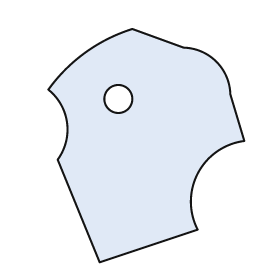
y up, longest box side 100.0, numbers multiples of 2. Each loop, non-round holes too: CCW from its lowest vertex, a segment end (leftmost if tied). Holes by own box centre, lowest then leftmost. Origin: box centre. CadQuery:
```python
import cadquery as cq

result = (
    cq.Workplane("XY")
    .moveTo(-20.0, -50.0)
    .lineTo(22.0, -36.0)
    .threePointArc((22.0, -12.0), (42.0, 2.0))
    .lineTo(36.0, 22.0)
    .threePointArc((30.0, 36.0), (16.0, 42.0))
    .lineTo(-6.0, 50.0)
    .threePointArc((-26.0, 40.0), (-42.0, 24.0))
    .threePointArc((-34.0, 10.0), (-38.0, -6.0))
    .close()
    .moveTo(-12.0, 20.0)
    .circle(6.0)
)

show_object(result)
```